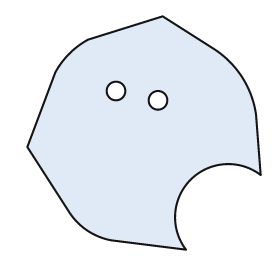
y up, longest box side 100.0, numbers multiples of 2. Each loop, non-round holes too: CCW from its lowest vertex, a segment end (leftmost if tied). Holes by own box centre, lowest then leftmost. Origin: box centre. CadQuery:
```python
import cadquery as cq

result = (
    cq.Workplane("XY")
    .moveTo(18.0, -50.0)
    .threePointArc((20.0, -20.0), (50.0, -18.0))
    .lineTo(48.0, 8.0)
    .threePointArc((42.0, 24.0), (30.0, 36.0))
    .lineTo(8.0, 50.0)
    .lineTo(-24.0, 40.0)
    .threePointArc((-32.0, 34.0), (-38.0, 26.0))
    .lineTo(-50.0, -6.0)
    .lineTo(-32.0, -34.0)
    .threePointArc((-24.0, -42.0), (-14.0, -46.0))
    .close()
    .moveTo(6.0, 14.0)
    .circle(4.0)
    .moveTo(-12.0, 18.0)
    .circle(4.0)
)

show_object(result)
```